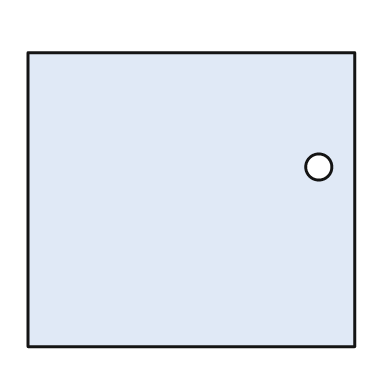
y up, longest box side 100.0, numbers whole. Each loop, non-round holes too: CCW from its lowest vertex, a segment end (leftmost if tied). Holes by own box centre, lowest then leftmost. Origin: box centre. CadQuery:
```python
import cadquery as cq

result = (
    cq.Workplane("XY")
    .moveTo(-50.0, -45.0)
    .lineTo(50.0, -45.0)
    .lineTo(50.0, 45.0)
    .lineTo(-50.0, 45.0)
    .close()
    .moveTo(39.0, 10.0)
    .circle(4.0)
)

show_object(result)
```